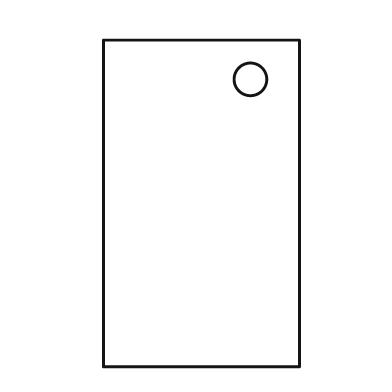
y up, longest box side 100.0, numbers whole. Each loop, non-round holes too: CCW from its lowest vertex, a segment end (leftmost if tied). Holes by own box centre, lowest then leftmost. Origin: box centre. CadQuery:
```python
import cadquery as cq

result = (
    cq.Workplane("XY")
    .moveTo(-30.0, -50.0)
    .lineTo(30.0, -50.0)
    .lineTo(30.0, 50.0)
    .lineTo(-30.0, 50.0)
    .close()
    .moveTo(15.0, 38.0)
    .circle(5.0)
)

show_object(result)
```